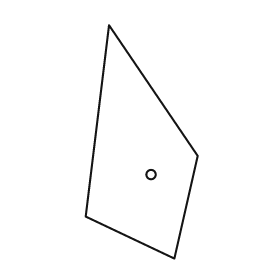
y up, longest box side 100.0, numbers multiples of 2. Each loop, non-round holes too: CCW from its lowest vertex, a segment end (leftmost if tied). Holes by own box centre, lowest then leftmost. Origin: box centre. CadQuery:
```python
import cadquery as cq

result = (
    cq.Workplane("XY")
    .moveTo(14.0, -50.0)
    .lineTo(24.0, -6.0)
    .lineTo(-14.0, 50.0)
    .lineTo(-24.0, -32.0)
    .close()
    .moveTo(4.0, -14.0)
    .circle(2.0)
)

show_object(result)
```